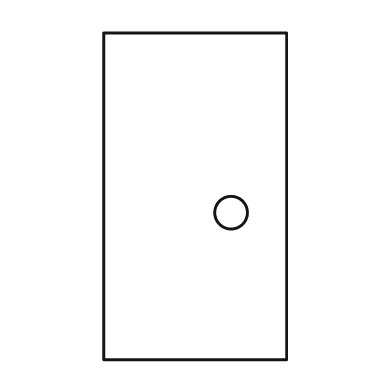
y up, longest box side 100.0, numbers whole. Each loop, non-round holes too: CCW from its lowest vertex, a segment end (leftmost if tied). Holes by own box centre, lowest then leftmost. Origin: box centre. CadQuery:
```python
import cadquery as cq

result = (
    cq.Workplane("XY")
    .moveTo(-28.0, -50.0)
    .lineTo(28.0, -50.0)
    .lineTo(28.0, 50.0)
    .lineTo(-28.0, 50.0)
    .close()
    .moveTo(11.0, -5.0)
    .circle(5.0)
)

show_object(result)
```